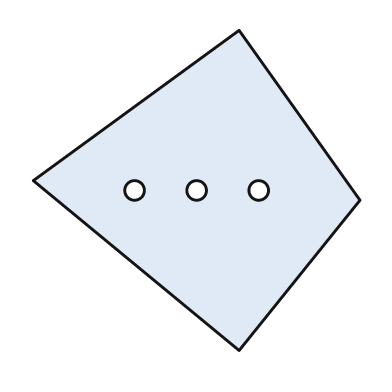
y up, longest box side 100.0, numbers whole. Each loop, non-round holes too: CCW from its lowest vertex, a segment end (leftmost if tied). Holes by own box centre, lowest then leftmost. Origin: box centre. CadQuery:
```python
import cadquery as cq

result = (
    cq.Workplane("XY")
    .moveTo(13.0, -49.0)
    .lineTo(50.0, -3.0)
    .lineTo(13.0, 49.0)
    .lineTo(-50.0, 3.0)
    .close()
    .moveTo(-19.0, 0.0)
    .circle(3.0)
    .moveTo(0.0, 0.0)
    .circle(3.0)
    .moveTo(19.0, 0.0)
    .circle(3.0)
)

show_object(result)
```